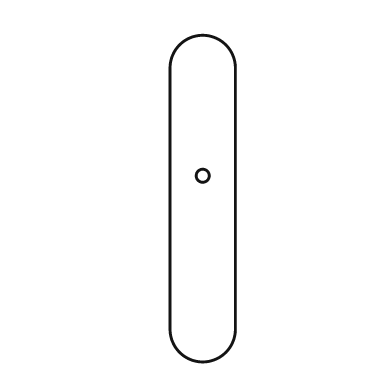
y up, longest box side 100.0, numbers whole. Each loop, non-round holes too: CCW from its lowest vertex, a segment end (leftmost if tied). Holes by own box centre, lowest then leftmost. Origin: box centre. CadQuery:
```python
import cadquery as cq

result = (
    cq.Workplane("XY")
    .moveTo(-10.0, -40.0)
    .threePointArc((0.0, -50.0), (10.0, -40.0))
    .lineTo(10.0, 40.0)
    .threePointArc((0.0, 50.0), (-10.0, 40.0))
    .close()
    .moveTo(0.0, 7.0)
    .circle(2.0)
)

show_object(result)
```